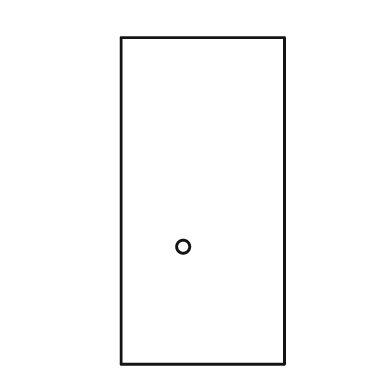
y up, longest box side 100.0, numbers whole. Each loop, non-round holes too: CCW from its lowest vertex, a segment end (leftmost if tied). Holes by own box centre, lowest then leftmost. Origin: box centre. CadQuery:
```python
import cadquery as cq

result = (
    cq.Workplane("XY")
    .moveTo(-25.0, -50.0)
    .lineTo(25.0, -50.0)
    .lineTo(25.0, 50.0)
    .lineTo(-25.0, 50.0)
    .close()
    .moveTo(-6.0, -14.0)
    .circle(2.0)
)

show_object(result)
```